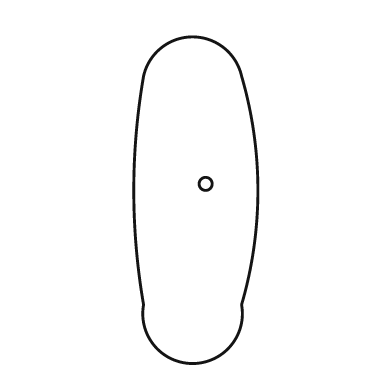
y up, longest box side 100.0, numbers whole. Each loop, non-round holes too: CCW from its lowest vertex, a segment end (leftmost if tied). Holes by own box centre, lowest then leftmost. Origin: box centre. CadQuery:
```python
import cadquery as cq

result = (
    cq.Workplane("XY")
    .moveTo(-16.0, -32.0)
    .threePointArc((-1.0, -50.0), (14.0, -32.0))
    .threePointArc((19.0, 3.0), (14.0, 38.0))
    .threePointArc((-1.0, 50.0), (-16.0, 38.0))
    .threePointArc((-19.0, 3.0), (-16.0, -32.0))
    .close()
    .moveTo(3.0, 5.0)
    .circle(2.0)
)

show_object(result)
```